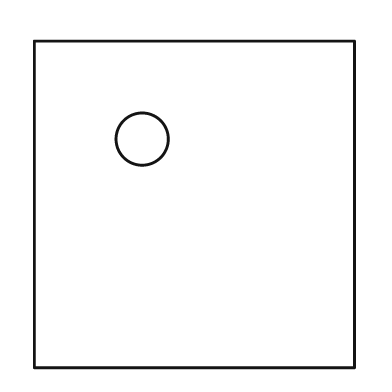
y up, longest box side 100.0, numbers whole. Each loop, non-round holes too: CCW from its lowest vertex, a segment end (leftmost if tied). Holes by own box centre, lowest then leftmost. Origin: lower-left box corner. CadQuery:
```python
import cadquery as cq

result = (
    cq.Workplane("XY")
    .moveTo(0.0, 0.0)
    .lineTo(98.0, 0.0)
    .lineTo(98.0, 100.0)
    .lineTo(0.0, 100.0)
    .close()
    .moveTo(33.0, 70.0)
    .circle(8.0)
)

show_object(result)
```